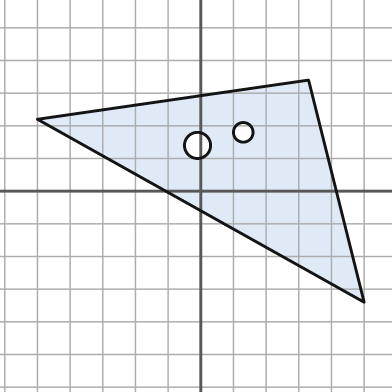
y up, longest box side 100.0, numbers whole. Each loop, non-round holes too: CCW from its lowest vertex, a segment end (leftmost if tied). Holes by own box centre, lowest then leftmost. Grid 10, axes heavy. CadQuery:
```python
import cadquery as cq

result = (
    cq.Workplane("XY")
    .moveTo(50.0, -34.0)
    .lineTo(33.0, 34.0)
    .lineTo(-50.0, 22.0)
    .close()
    .moveTo(-1.0, 14.0)
    .circle(4.0)
    .moveTo(13.0, 18.0)
    .circle(3.0)
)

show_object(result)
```